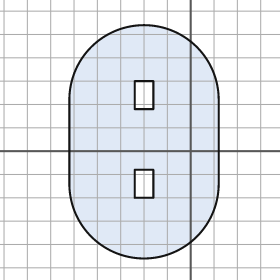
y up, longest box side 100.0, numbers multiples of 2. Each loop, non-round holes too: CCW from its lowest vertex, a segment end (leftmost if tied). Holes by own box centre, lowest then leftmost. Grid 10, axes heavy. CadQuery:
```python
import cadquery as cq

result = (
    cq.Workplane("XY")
    .moveTo(-52.0, -14.0)
    .threePointArc((-20.0, -46.0), (12.0, -14.0))
    .lineTo(12.0, 22.0)
    .threePointArc((-20.0, 54.0), (-52.0, 22.0))
    .close()
    .moveTo(-24.0, -20.0)
    .lineTo(-16.0, -20.0)
    .lineTo(-16.0, -8.0)
    .lineTo(-24.0, -8.0)
    .close()
    .moveTo(-24.0, 18.0)
    .lineTo(-16.0, 18.0)
    .lineTo(-16.0, 30.0)
    .lineTo(-24.0, 30.0)
    .close()
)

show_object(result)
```